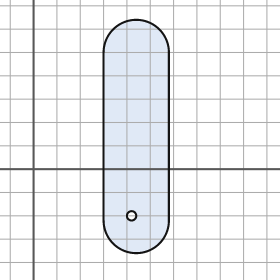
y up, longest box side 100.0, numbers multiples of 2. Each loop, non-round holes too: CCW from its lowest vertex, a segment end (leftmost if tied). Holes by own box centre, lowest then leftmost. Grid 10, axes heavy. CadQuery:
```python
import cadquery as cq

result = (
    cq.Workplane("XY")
    .moveTo(30.0, -22.0)
    .threePointArc((44.0, -36.0), (58.0, -22.0))
    .lineTo(58.0, 50.0)
    .threePointArc((44.0, 64.0), (30.0, 50.0))
    .close()
    .moveTo(42.0, -20.0)
    .circle(2.0)
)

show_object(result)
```